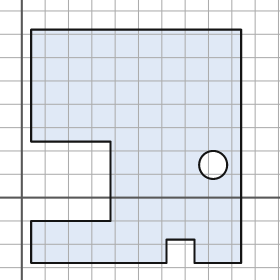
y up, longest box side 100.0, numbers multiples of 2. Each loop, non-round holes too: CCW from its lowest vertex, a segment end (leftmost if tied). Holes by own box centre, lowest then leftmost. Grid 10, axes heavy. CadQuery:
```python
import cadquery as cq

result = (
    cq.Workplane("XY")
    .moveTo(4.0, -28.0)
    .lineTo(62.0, -28.0)
    .lineTo(62.0, -18.0)
    .lineTo(74.0, -18.0)
    .lineTo(74.0, -28.0)
    .lineTo(94.0, -28.0)
    .lineTo(94.0, 72.0)
    .lineTo(4.0, 72.0)
    .lineTo(4.0, 24.0)
    .lineTo(38.0, 24.0)
    .lineTo(38.0, -10.0)
    .lineTo(4.0, -10.0)
    .close()
    .moveTo(82.0, 14.0)
    .circle(6.0)
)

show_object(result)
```